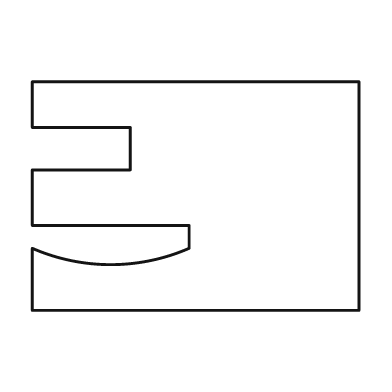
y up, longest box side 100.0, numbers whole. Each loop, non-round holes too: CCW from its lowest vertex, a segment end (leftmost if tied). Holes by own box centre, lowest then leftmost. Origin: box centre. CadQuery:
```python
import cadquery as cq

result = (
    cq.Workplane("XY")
    .moveTo(-50.0, -35.0)
    .lineTo(50.0, -35.0)
    .lineTo(50.0, 35.0)
    .lineTo(-50.0, 35.0)
    .lineTo(-50.0, 21.0)
    .lineTo(-20.0, 21.0)
    .lineTo(-20.0, 8.0)
    .lineTo(-50.0, 8.0)
    .lineTo(-50.0, -9.0)
    .lineTo(-2.0, -9.0)
    .lineTo(-2.0, -16.0)
    .threePointArc((-26.0, -21.0), (-50.0, -16.0))
    .close()
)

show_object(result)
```